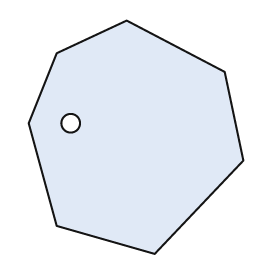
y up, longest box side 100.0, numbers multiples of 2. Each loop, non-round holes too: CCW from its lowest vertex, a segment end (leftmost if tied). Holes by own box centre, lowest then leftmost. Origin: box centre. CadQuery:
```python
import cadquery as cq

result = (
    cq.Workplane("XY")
    .moveTo(8.0, -50.0)
    .lineTo(46.0, -10.0)
    .lineTo(38.0, 28.0)
    .lineTo(-4.0, 50.0)
    .lineTo(-34.0, 36.0)
    .lineTo(-46.0, 6.0)
    .lineTo(-34.0, -38.0)
    .close()
    .moveTo(-28.0, 6.0)
    .circle(4.0)
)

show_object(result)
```